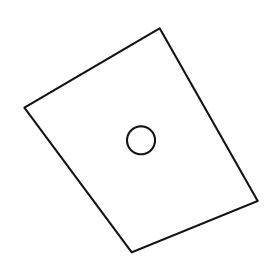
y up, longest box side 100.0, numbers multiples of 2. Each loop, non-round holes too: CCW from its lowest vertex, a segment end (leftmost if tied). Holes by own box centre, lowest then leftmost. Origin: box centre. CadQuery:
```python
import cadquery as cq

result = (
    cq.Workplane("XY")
    .moveTo(-4.0, -48.0)
    .lineTo(50.0, -26.0)
    .lineTo(8.0, 48.0)
    .lineTo(-50.0, 14.0)
    .close()
    .moveTo(0.0, 0.0)
    .circle(6.0)
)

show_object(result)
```